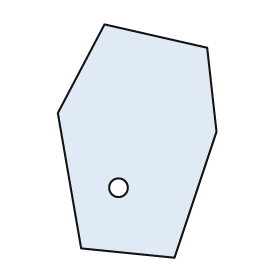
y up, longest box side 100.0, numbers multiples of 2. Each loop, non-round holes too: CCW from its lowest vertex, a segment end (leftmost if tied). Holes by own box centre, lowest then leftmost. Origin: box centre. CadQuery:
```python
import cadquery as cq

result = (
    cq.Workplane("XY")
    .moveTo(16.0, -50.0)
    .lineTo(34.0, 4.0)
    .lineTo(30.0, 40.0)
    .lineTo(-14.0, 50.0)
    .lineTo(-34.0, 12.0)
    .lineTo(-24.0, -46.0)
    .close()
    .moveTo(-8.0, -20.0)
    .circle(4.0)
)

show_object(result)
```